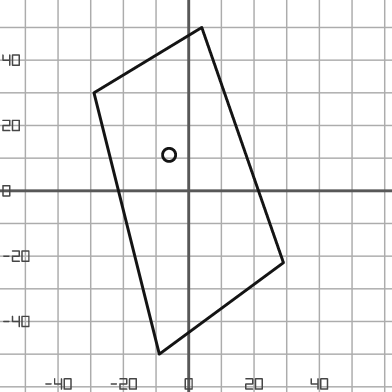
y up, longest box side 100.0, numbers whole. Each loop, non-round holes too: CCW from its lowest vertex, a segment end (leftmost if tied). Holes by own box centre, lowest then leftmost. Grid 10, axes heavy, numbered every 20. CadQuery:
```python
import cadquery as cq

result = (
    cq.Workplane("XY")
    .moveTo(-9.0, -50.0)
    .lineTo(29.0, -22.0)
    .lineTo(4.0, 50.0)
    .lineTo(-29.0, 30.0)
    .close()
    .moveTo(-6.0, 11.0)
    .circle(2.0)
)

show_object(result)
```